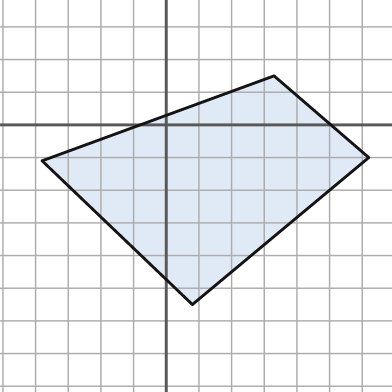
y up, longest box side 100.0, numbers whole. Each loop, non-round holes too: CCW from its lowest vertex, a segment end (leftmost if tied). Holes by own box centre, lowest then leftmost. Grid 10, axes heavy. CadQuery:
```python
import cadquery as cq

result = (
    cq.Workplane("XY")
    .moveTo(8.0, -55.0)
    .lineTo(62.0, -10.0)
    .lineTo(33.0, 15.0)
    .lineTo(-38.0, -11.0)
    .close()
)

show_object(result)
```